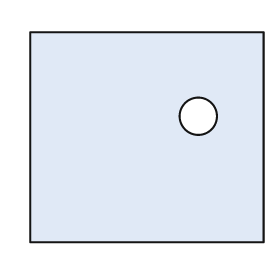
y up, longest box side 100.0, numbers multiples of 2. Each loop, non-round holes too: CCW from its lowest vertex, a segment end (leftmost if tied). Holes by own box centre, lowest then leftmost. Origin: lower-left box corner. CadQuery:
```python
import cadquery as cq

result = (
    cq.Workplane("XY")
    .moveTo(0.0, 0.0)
    .lineTo(100.0, 0.0)
    .lineTo(100.0, 90.0)
    .lineTo(0.0, 90.0)
    .close()
    .moveTo(72.0, 54.0)
    .circle(8.0)
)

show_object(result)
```